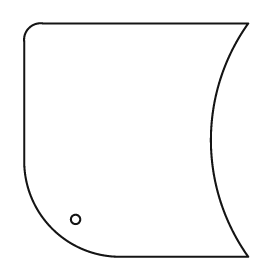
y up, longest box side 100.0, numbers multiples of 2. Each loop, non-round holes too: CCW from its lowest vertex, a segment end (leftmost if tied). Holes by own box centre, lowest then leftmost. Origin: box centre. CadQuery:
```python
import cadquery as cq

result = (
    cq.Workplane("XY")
    .moveTo(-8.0, -50.0)
    .lineTo(48.0, -50.0)
    .threePointArc((32.0, 0.0), (48.0, 50.0))
    .lineTo(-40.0, 50.0)
    .threePointArc((-46.0, 48.0), (-48.0, 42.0))
    .lineTo(-48.0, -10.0)
    .threePointArc((-36.0, -38.0), (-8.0, -50.0))
    .close()
    .moveTo(-26.0, -34.0)
    .circle(2.0)
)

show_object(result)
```